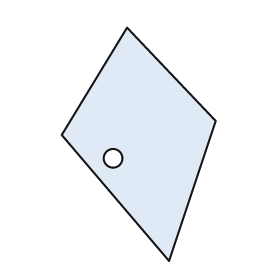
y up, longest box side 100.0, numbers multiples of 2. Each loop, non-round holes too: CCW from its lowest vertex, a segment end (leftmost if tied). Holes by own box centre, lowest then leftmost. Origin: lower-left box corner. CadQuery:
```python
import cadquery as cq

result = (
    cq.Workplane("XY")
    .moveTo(46.0, 0.0)
    .lineTo(66.0, 60.0)
    .lineTo(28.0, 100.0)
    .lineTo(0.0, 54.0)
    .close()
    .moveTo(22.0, 44.0)
    .circle(4.0)
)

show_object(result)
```